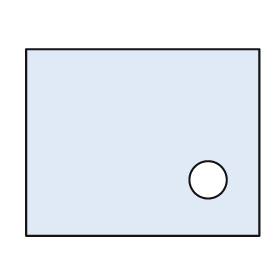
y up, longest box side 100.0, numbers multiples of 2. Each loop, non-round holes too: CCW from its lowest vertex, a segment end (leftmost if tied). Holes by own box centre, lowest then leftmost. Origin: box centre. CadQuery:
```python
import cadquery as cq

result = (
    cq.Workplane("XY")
    .moveTo(-50.0, -40.0)
    .lineTo(50.0, -40.0)
    .lineTo(50.0, 40.0)
    .lineTo(-50.0, 40.0)
    .close()
    .moveTo(28.0, -16.0)
    .circle(8.0)
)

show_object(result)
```